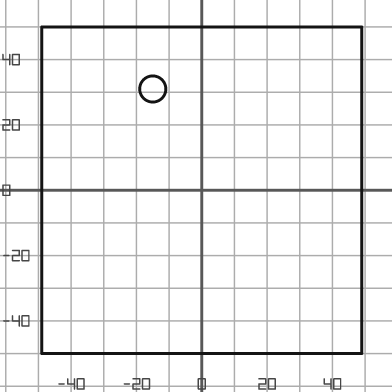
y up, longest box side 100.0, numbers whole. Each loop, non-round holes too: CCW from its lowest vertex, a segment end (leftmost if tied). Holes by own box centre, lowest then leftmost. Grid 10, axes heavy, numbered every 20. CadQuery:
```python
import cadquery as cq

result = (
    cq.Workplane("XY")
    .moveTo(-49.0, -50.0)
    .lineTo(49.0, -50.0)
    .lineTo(49.0, 50.0)
    .lineTo(-49.0, 50.0)
    .close()
    .moveTo(-15.0, 31.0)
    .circle(4.0)
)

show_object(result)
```